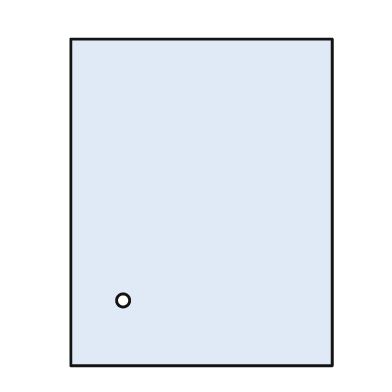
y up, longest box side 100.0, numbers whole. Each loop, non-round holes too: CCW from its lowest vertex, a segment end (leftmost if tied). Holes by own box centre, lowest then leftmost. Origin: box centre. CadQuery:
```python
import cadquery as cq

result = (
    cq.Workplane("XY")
    .moveTo(-40.0, -50.0)
    .lineTo(40.0, -50.0)
    .lineTo(40.0, 50.0)
    .lineTo(-40.0, 50.0)
    .close()
    .moveTo(-24.0, -30.0)
    .circle(2.0)
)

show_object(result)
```